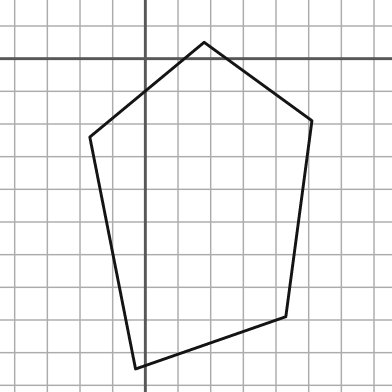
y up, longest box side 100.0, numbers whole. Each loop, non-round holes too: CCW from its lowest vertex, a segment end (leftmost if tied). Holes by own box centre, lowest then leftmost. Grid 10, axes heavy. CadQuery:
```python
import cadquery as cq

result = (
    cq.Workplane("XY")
    .moveTo(-3.0, -95.0)
    .lineTo(43.0, -79.0)
    .lineTo(51.0, -19.0)
    .lineTo(18.0, 5.0)
    .lineTo(-17.0, -24.0)
    .close()
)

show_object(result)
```